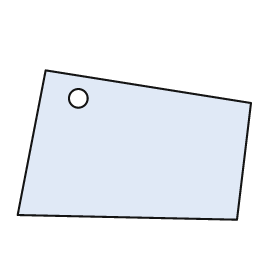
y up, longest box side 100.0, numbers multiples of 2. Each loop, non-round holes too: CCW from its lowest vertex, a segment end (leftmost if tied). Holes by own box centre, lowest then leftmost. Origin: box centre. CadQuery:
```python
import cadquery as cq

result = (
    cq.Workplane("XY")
    .moveTo(44.0, -32.0)
    .lineTo(50.0, 18.0)
    .lineTo(-38.0, 32.0)
    .lineTo(-50.0, -30.0)
    .close()
    .moveTo(-24.0, 20.0)
    .circle(4.0)
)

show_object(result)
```